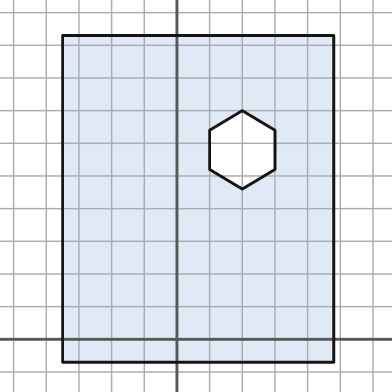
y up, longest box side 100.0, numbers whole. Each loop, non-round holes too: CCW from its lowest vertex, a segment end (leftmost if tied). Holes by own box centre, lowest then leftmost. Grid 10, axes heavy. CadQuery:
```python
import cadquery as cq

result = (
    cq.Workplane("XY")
    .moveTo(-35.0, -7.0)
    .lineTo(48.0, -7.0)
    .lineTo(48.0, 93.0)
    .lineTo(-35.0, 93.0)
    .close()
    .moveTo(20.0, 46.0)
    .lineTo(30.0, 52.0)
    .lineTo(30.0, 64.0)
    .lineTo(20.0, 70.0)
    .lineTo(10.0, 64.0)
    .lineTo(10.0, 52.0)
    .close()
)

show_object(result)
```